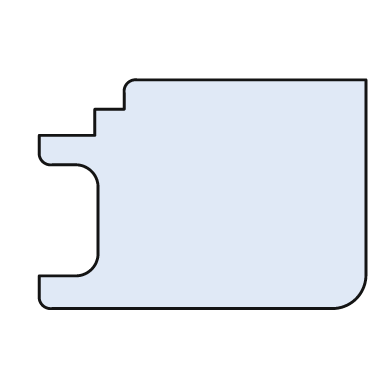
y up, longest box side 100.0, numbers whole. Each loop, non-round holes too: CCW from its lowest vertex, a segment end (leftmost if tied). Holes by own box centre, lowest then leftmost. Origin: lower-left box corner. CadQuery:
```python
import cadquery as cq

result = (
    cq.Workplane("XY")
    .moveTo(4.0, 0.0)
    .lineTo(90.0, 0.0)
    .threePointArc((97.0, 3.0), (100.0, 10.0))
    .lineTo(100.0, 70.0)
    .lineTo(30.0, 70.0)
    .threePointArc((27.0, 69.0), (26.0, 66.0))
    .lineTo(26.0, 61.0)
    .lineTo(17.0, 61.0)
    .lineTo(17.0, 53.0)
    .lineTo(0.0, 53.0)
    .lineTo(0.0, 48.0)
    .threePointArc((1.0, 45.0), (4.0, 44.0))
    .lineTo(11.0, 44.0)
    .threePointArc((16.0, 42.0), (18.0, 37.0))
    .lineTo(18.0, 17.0)
    .threePointArc((16.0, 12.0), (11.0, 10.0))
    .lineTo(0.0, 10.0)
    .lineTo(0.0, 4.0)
    .threePointArc((1.0, 1.0), (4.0, 0.0))
    .close()
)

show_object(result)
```